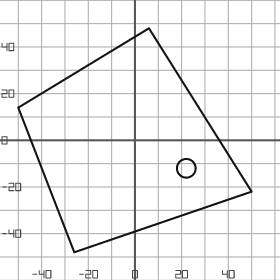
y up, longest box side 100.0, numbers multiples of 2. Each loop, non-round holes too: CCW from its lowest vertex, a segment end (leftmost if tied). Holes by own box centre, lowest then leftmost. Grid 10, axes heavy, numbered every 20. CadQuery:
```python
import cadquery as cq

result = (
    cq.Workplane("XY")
    .moveTo(-26.0, -48.0)
    .lineTo(50.0, -22.0)
    .lineTo(6.0, 48.0)
    .lineTo(-50.0, 14.0)
    .close()
    .moveTo(22.0, -12.0)
    .circle(4.0)
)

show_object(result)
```